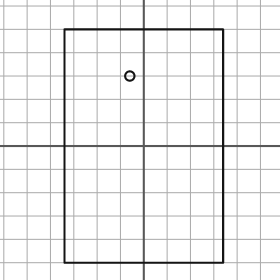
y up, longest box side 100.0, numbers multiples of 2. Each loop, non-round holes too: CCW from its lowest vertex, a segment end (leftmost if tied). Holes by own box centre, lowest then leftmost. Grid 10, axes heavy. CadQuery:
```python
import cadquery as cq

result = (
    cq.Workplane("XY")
    .moveTo(-34.0, -50.0)
    .lineTo(34.0, -50.0)
    .lineTo(34.0, 50.0)
    .lineTo(-34.0, 50.0)
    .close()
    .moveTo(-6.0, 30.0)
    .circle(2.0)
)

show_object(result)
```